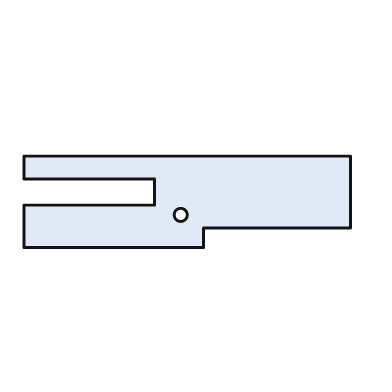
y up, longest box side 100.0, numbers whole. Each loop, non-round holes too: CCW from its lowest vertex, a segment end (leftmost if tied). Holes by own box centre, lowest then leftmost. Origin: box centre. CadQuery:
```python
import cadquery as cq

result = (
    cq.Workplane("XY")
    .moveTo(-50.0, -14.0)
    .lineTo(5.0, -14.0)
    .lineTo(5.0, -8.0)
    .lineTo(50.0, -8.0)
    .lineTo(50.0, 14.0)
    .lineTo(-50.0, 14.0)
    .lineTo(-50.0, 7.0)
    .lineTo(-10.0, 7.0)
    .lineTo(-10.0, -1.0)
    .lineTo(-50.0, -1.0)
    .close()
    .moveTo(-2.0, -4.0)
    .circle(2.0)
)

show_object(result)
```